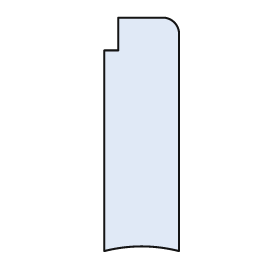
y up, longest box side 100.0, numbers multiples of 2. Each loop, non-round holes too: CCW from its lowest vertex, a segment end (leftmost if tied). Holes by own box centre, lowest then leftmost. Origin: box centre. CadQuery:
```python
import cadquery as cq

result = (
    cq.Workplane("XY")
    .moveTo(-16.0, -50.0)
    .threePointArc((0.0, -48.0), (16.0, -50.0))
    .lineTo(16.0, 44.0)
    .threePointArc((14.0, 48.0), (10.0, 50.0))
    .lineTo(-10.0, 50.0)
    .lineTo(-10.0, 36.0)
    .lineTo(-16.0, 36.0)
    .close()
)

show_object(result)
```